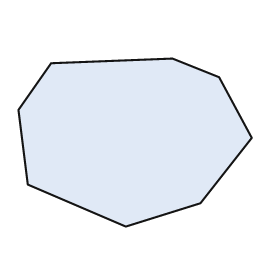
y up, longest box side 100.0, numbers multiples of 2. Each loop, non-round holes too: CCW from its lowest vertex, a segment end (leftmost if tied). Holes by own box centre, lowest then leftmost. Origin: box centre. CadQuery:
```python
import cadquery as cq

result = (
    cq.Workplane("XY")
    .moveTo(-4.0, -36.0)
    .lineTo(28.0, -26.0)
    .lineTo(50.0, 2.0)
    .lineTo(36.0, 28.0)
    .lineTo(16.0, 36.0)
    .lineTo(-36.0, 34.0)
    .lineTo(-50.0, 14.0)
    .lineTo(-46.0, -18.0)
    .close()
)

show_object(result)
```